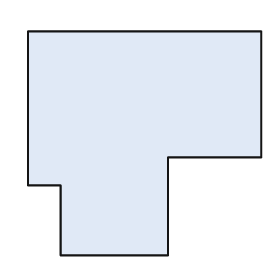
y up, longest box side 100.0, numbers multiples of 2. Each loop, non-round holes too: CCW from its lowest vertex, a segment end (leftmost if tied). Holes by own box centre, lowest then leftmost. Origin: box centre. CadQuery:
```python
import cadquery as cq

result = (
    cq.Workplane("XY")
    .moveTo(-36.0, -48.0)
    .lineTo(10.0, -48.0)
    .lineTo(10.0, -6.0)
    .lineTo(50.0, -6.0)
    .lineTo(50.0, 48.0)
    .lineTo(-50.0, 48.0)
    .lineTo(-50.0, -18.0)
    .lineTo(-36.0, -18.0)
    .close()
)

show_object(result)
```